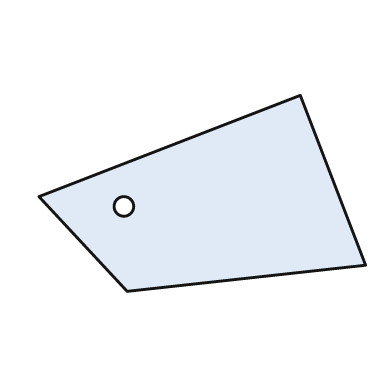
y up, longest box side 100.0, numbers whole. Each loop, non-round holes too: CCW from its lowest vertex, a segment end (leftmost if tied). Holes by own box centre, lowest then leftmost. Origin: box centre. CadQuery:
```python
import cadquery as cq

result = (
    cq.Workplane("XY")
    .moveTo(-23.0, -30.0)
    .lineTo(50.0, -22.0)
    .lineTo(30.0, 30.0)
    .lineTo(-50.0, -1.0)
    .close()
    .moveTo(-24.0, -4.0)
    .circle(3.0)
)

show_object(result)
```